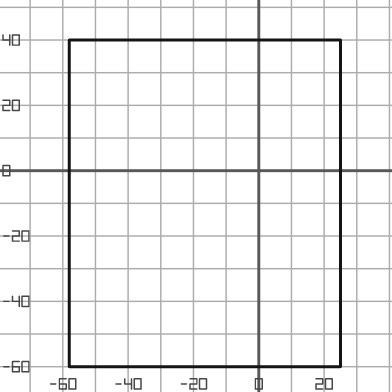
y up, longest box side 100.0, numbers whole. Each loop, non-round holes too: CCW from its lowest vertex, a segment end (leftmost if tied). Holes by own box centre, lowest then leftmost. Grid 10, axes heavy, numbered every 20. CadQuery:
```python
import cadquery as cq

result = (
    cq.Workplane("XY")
    .moveTo(-58.0, -60.0)
    .lineTo(25.0, -60.0)
    .lineTo(25.0, 40.0)
    .lineTo(-58.0, 40.0)
    .close()
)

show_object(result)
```